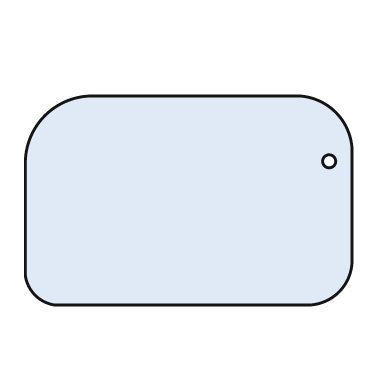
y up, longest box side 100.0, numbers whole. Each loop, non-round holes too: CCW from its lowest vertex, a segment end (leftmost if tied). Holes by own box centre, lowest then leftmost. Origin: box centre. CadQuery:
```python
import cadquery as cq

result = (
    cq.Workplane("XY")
    .moveTo(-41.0, -32.0)
    .lineTo(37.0, -32.0)
    .threePointArc((46.0, -28.0), (50.0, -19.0))
    .lineTo(50.0, 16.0)
    .threePointArc((45.0, 27.0), (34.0, 32.0))
    .lineTo(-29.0, 32.0)
    .threePointArc((-44.0, 26.0), (-50.0, 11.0))
    .lineTo(-50.0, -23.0)
    .threePointArc((-47.0, -29.0), (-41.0, -32.0))
    .close()
    .moveTo(43.0, 12.0)
    .circle(2.0)
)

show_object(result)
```